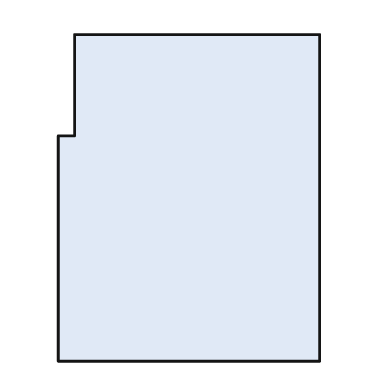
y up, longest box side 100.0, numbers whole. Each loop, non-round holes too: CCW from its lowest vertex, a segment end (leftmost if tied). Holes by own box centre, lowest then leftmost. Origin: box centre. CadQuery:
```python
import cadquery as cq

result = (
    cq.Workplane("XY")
    .moveTo(-40.0, -50.0)
    .lineTo(40.0, -50.0)
    .lineTo(40.0, 50.0)
    .lineTo(-35.0, 50.0)
    .lineTo(-35.0, 19.0)
    .lineTo(-40.0, 19.0)
    .close()
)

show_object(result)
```